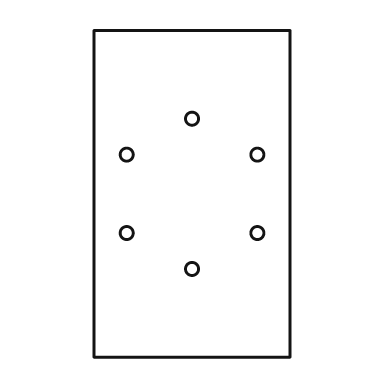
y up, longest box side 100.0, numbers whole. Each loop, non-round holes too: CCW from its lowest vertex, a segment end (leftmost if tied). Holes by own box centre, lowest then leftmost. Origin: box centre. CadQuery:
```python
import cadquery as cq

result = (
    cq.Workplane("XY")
    .moveTo(-30.0, -50.0)
    .lineTo(30.0, -50.0)
    .lineTo(30.0, 50.0)
    .lineTo(-30.0, 50.0)
    .close()
    .moveTo(0.0, -23.0)
    .circle(2.0)
    .moveTo(-20.0, -12.0)
    .circle(2.0)
    .moveTo(20.0, -12.0)
    .circle(2.0)
    .moveTo(-20.0, 12.0)
    .circle(2.0)
    .moveTo(20.0, 12.0)
    .circle(2.0)
    .moveTo(0.0, 23.0)
    .circle(2.0)
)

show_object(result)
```